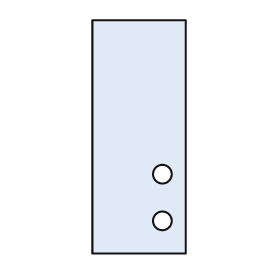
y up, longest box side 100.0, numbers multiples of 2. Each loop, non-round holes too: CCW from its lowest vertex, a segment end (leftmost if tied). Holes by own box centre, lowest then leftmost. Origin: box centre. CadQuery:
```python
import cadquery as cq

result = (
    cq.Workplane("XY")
    .moveTo(-20.0, -50.0)
    .lineTo(20.0, -50.0)
    .lineTo(20.0, 50.0)
    .lineTo(-20.0, 50.0)
    .close()
    .moveTo(10.0, -36.0)
    .circle(4.0)
    .moveTo(10.0, -16.0)
    .circle(4.0)
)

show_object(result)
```